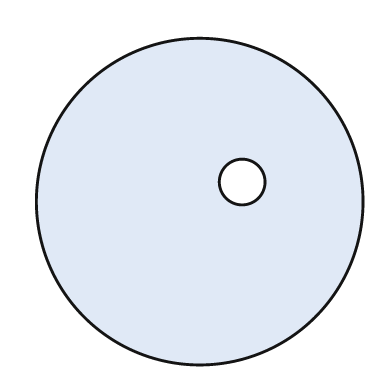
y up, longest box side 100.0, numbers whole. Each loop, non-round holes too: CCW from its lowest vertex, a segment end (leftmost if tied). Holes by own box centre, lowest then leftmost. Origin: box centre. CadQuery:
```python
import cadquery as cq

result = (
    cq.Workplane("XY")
    .moveTo(0.0, 0.0)
    .circle(50.0)
    .moveTo(13.0, 6.0)
    .circle(7.0)
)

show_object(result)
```